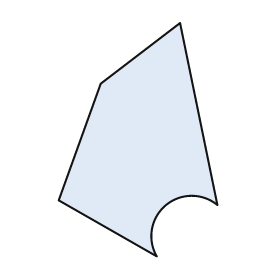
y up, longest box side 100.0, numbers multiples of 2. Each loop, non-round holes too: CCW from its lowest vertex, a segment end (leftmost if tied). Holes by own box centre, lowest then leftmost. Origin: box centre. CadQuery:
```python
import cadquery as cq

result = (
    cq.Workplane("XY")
    .moveTo(8.0, -50.0)
    .threePointArc((12.0, -28.0), (34.0, -28.0))
    .lineTo(18.0, 50.0)
    .lineTo(-16.0, 24.0)
    .lineTo(-34.0, -26.0)
    .close()
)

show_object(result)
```